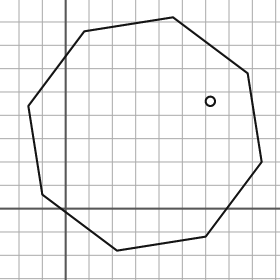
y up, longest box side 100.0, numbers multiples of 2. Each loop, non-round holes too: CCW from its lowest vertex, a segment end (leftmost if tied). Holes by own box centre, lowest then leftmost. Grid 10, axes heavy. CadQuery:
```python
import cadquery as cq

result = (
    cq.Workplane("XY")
    .moveTo(22.0, -18.0)
    .lineTo(60.0, -12.0)
    .lineTo(84.0, 20.0)
    .lineTo(78.0, 58.0)
    .lineTo(46.0, 82.0)
    .lineTo(8.0, 76.0)
    .lineTo(-16.0, 44.0)
    .lineTo(-10.0, 6.0)
    .close()
    .moveTo(62.0, 46.0)
    .circle(2.0)
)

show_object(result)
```